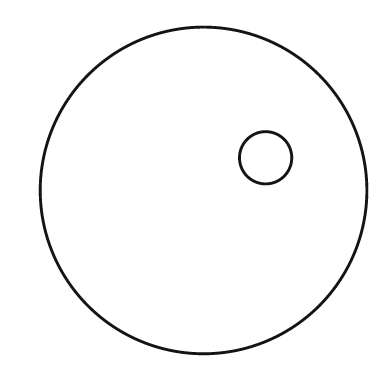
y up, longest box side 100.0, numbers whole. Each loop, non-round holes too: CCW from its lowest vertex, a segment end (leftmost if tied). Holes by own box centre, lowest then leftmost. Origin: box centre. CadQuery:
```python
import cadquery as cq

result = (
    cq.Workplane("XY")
    .moveTo(0.0, 0.0)
    .circle(50.0)
    .moveTo(19.0, 10.0)
    .circle(8.0)
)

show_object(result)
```